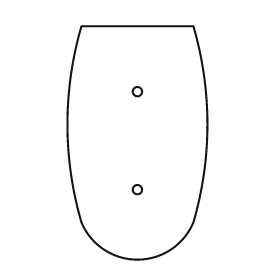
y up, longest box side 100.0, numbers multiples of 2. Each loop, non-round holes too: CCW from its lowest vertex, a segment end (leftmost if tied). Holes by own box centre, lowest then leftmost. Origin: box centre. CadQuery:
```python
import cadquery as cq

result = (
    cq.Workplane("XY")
    .moveTo(-24.0, -34.0)
    .threePointArc((0.0, -50.0), (24.0, -34.0))
    .threePointArc((30.0, 8.0), (24.0, 50.0))
    .lineTo(-24.0, 50.0)
    .threePointArc((-30.0, 8.0), (-24.0, -34.0))
    .close()
    .moveTo(0.0, -20.0)
    .circle(2.0)
    .moveTo(0.0, 22.0)
    .circle(2.0)
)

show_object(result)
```